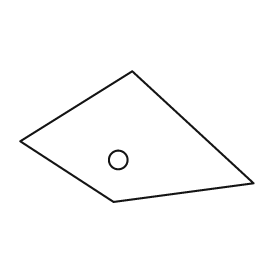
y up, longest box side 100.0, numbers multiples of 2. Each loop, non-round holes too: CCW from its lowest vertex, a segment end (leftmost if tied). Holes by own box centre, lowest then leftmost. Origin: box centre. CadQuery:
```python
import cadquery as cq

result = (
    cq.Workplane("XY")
    .moveTo(-10.0, -28.0)
    .lineTo(50.0, -20.0)
    .lineTo(-2.0, 28.0)
    .lineTo(-50.0, -2.0)
    .close()
    .moveTo(-8.0, -10.0)
    .circle(4.0)
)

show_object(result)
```